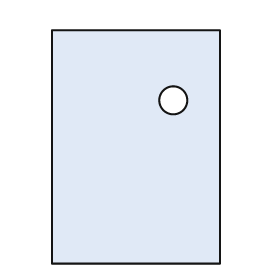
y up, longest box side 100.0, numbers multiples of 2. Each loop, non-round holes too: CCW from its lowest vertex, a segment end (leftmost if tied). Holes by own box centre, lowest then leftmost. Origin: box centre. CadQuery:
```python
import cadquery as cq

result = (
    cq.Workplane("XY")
    .moveTo(-36.0, -50.0)
    .lineTo(36.0, -50.0)
    .lineTo(36.0, 50.0)
    .lineTo(-36.0, 50.0)
    .close()
    .moveTo(16.0, 20.0)
    .circle(6.0)
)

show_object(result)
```